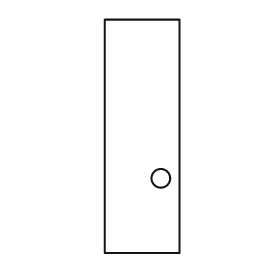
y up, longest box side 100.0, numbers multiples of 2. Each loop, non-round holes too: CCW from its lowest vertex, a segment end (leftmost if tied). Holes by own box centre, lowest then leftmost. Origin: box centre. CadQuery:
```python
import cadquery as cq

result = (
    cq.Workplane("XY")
    .moveTo(-16.0, -50.0)
    .lineTo(16.0, -50.0)
    .lineTo(16.0, 50.0)
    .lineTo(-16.0, 50.0)
    .close()
    .moveTo(8.0, -18.0)
    .circle(4.0)
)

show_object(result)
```